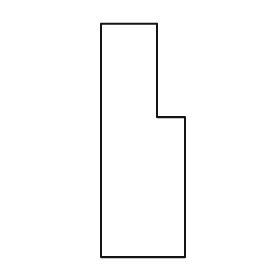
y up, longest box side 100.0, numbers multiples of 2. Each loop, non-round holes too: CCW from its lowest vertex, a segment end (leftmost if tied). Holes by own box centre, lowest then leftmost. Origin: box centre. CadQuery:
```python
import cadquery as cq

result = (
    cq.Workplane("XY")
    .moveTo(-18.0, -50.0)
    .lineTo(18.0, -50.0)
    .lineTo(18.0, 10.0)
    .lineTo(6.0, 10.0)
    .lineTo(6.0, 50.0)
    .lineTo(-18.0, 50.0)
    .close()
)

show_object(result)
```